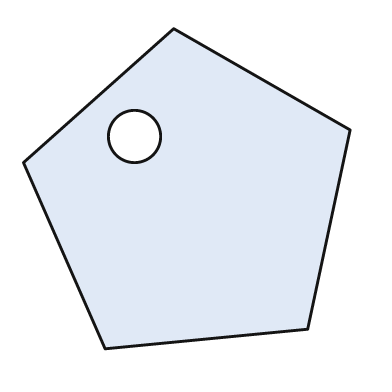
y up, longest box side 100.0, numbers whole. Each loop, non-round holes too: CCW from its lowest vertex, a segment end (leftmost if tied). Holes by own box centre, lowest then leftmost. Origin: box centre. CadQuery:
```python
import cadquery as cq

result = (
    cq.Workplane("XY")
    .moveTo(-25.0, -49.0)
    .lineTo(37.0, -43.0)
    .lineTo(50.0, 18.0)
    .lineTo(-4.0, 49.0)
    .lineTo(-50.0, 8.0)
    .close()
    .moveTo(-16.0, 16.0)
    .circle(8.0)
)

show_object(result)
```